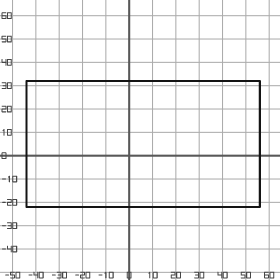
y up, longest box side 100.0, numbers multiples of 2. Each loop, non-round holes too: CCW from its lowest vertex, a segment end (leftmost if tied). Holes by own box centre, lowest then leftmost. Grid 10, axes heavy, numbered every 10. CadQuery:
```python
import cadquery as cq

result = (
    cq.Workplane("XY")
    .moveTo(-44.0, -22.0)
    .lineTo(56.0, -22.0)
    .lineTo(56.0, 32.0)
    .lineTo(-44.0, 32.0)
    .close()
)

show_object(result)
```